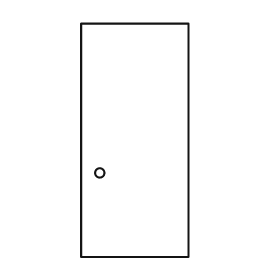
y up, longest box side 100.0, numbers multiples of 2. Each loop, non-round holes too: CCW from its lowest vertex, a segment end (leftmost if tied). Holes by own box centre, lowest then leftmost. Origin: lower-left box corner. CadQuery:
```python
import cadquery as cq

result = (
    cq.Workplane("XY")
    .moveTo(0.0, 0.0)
    .lineTo(46.0, 0.0)
    .lineTo(46.0, 100.0)
    .lineTo(0.0, 100.0)
    .close()
    .moveTo(8.0, 36.0)
    .circle(2.0)
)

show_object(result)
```